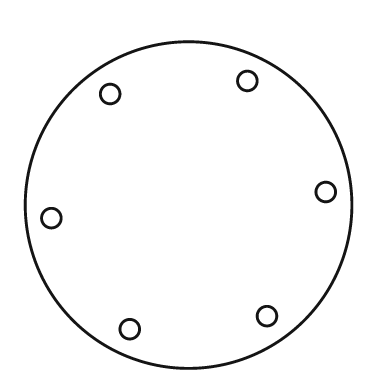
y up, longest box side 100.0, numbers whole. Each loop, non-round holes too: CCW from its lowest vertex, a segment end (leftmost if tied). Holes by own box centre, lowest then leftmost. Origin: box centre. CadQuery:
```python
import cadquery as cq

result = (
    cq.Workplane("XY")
    .moveTo(0.0, 0.0)
    .circle(50.0)
    .moveTo(-18.0, -38.0)
    .circle(3.0)
    .moveTo(24.0, -34.0)
    .circle(3.0)
    .moveTo(-42.0, -4.0)
    .circle(3.0)
    .moveTo(42.0, 4.0)
    .circle(3.0)
    .moveTo(-24.0, 34.0)
    .circle(3.0)
    .moveTo(18.0, 38.0)
    .circle(3.0)
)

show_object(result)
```